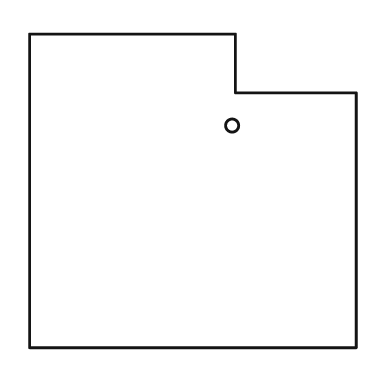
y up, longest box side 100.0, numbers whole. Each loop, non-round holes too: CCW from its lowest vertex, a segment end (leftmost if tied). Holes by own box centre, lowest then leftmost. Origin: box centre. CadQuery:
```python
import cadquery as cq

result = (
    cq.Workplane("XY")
    .moveTo(-50.0, -48.0)
    .lineTo(50.0, -48.0)
    .lineTo(50.0, 30.0)
    .lineTo(13.0, 30.0)
    .lineTo(13.0, 48.0)
    .lineTo(-50.0, 48.0)
    .close()
    .moveTo(12.0, 20.0)
    .circle(2.0)
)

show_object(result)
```